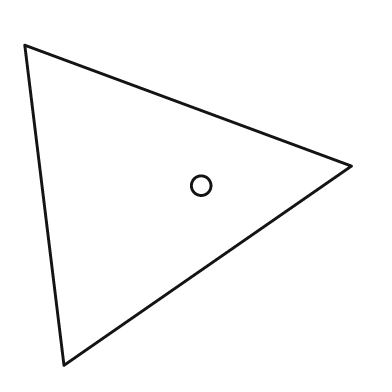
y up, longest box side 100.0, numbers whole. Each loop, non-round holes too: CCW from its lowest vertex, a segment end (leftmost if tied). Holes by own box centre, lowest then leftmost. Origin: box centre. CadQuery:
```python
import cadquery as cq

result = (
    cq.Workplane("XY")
    .moveTo(-38.0, -49.0)
    .lineTo(50.0, 12.0)
    .lineTo(-50.0, 49.0)
    .close()
    .moveTo(4.0, 6.0)
    .circle(3.0)
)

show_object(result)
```